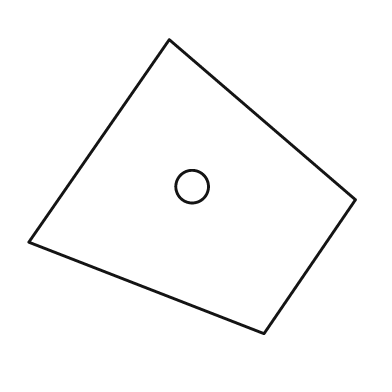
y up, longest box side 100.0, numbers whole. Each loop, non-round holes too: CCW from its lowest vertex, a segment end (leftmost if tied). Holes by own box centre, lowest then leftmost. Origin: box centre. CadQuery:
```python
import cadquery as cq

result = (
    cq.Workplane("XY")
    .moveTo(22.0, -45.0)
    .lineTo(50.0, -4.0)
    .lineTo(-7.0, 45.0)
    .lineTo(-50.0, -17.0)
    .close()
    .moveTo(0.0, 0.0)
    .circle(5.0)
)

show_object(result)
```